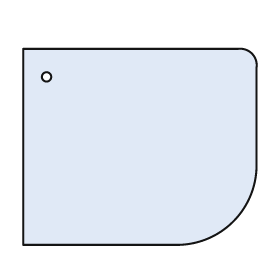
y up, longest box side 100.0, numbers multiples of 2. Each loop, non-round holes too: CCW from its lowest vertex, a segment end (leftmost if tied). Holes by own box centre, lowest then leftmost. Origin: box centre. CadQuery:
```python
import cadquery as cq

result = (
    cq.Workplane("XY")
    .moveTo(-50.0, -42.0)
    .lineTo(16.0, -42.0)
    .threePointArc((40.0, -32.0), (50.0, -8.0))
    .lineTo(50.0, 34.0)
    .threePointArc((48.0, 40.0), (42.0, 42.0))
    .lineTo(-50.0, 42.0)
    .close()
    .moveTo(-40.0, 30.0)
    .circle(2.0)
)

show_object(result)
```